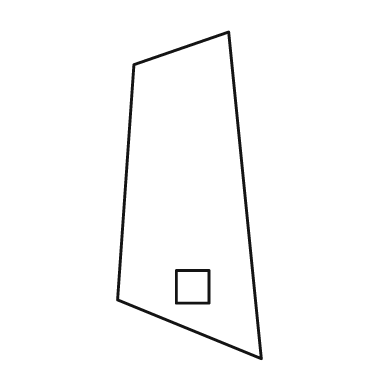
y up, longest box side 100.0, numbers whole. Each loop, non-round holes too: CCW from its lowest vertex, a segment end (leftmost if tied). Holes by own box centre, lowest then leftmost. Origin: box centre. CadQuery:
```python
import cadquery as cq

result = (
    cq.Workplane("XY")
    .moveTo(22.0, -50.0)
    .lineTo(12.0, 50.0)
    .lineTo(-17.0, 40.0)
    .lineTo(-22.0, -32.0)
    .close()
    .moveTo(-4.0, -33.0)
    .lineTo(6.0, -33.0)
    .lineTo(6.0, -23.0)
    .lineTo(-4.0, -23.0)
    .close()
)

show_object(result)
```